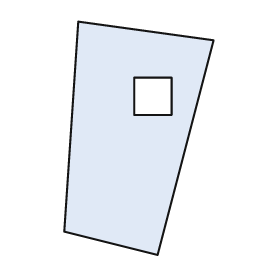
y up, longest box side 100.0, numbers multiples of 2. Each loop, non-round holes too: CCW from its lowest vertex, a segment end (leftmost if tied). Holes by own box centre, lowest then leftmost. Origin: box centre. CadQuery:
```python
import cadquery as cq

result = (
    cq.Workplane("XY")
    .moveTo(8.0, -50.0)
    .lineTo(32.0, 42.0)
    .lineTo(-26.0, 50.0)
    .lineTo(-32.0, -40.0)
    .close()
    .moveTo(-2.0, 10.0)
    .lineTo(14.0, 10.0)
    .lineTo(14.0, 26.0)
    .lineTo(-2.0, 26.0)
    .close()
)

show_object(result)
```